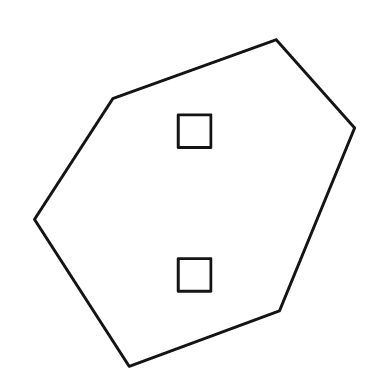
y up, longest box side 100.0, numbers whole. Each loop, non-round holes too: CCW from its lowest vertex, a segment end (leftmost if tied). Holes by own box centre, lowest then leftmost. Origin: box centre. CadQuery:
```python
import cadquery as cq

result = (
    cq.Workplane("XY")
    .moveTo(-20.0, -50.0)
    .lineTo(26.0, -33.0)
    .lineTo(49.0, 23.0)
    .lineTo(25.0, 50.0)
    .lineTo(-25.0, 32.0)
    .lineTo(-49.0, -5.0)
    .close()
    .moveTo(-5.0, -27.0)
    .lineTo(5.0, -27.0)
    .lineTo(5.0, -17.0)
    .lineTo(-5.0, -17.0)
    .close()
    .moveTo(-5.0, 17.0)
    .lineTo(5.0, 17.0)
    .lineTo(5.0, 27.0)
    .lineTo(-5.0, 27.0)
    .close()
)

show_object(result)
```